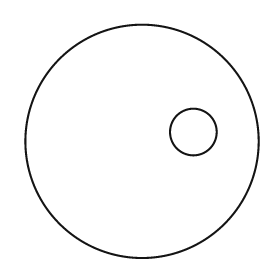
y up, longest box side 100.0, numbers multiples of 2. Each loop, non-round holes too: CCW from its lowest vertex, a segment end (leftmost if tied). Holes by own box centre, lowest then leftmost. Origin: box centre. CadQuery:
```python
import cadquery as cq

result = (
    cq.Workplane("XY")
    .moveTo(0.0, 0.0)
    .circle(50.0)
    .moveTo(22.0, 4.0)
    .circle(10.0)
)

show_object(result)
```